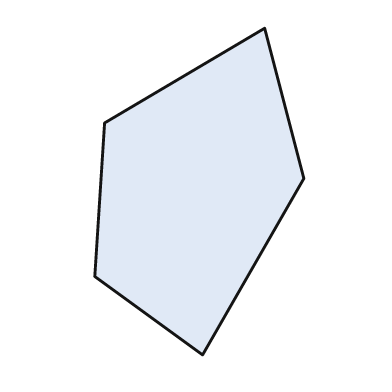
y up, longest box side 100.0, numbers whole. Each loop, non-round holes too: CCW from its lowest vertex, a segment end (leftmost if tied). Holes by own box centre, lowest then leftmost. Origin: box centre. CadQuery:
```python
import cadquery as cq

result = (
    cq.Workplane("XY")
    .moveTo(1.0, -50.0)
    .lineTo(32.0, 4.0)
    .lineTo(20.0, 50.0)
    .lineTo(-29.0, 21.0)
    .lineTo(-32.0, -26.0)
    .close()
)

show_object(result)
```